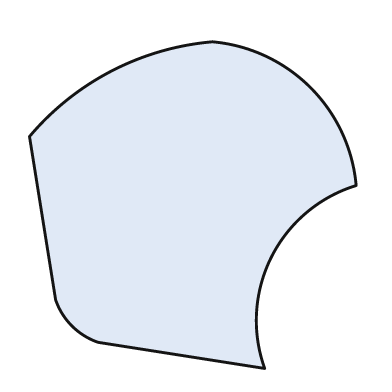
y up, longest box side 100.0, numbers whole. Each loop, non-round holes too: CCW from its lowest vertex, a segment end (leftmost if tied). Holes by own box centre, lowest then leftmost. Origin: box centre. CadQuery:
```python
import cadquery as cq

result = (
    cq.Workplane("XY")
    .moveTo(22.0, -50.0)
    .threePointArc((24.0, -16.0), (50.0, 6.0))
    .threePointArc((36.0, 36.0), (6.0, 50.0))
    .threePointArc((-25.0, 41.0), (-50.0, 21.0))
    .lineTo(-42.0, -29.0)
    .threePointArc((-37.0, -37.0), (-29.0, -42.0))
    .close()
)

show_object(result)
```